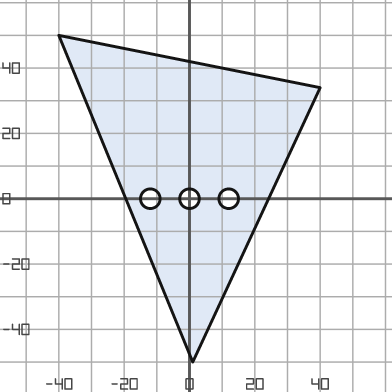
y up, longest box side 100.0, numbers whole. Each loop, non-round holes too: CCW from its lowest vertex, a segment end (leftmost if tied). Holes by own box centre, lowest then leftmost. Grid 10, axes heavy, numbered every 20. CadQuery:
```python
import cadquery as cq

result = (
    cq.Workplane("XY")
    .moveTo(1.0, -50.0)
    .lineTo(40.0, 34.0)
    .lineTo(-40.0, 50.0)
    .close()
    .moveTo(-12.0, 0.0)
    .circle(3.0)
    .moveTo(0.0, 0.0)
    .circle(3.0)
    .moveTo(12.0, 0.0)
    .circle(3.0)
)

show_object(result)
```